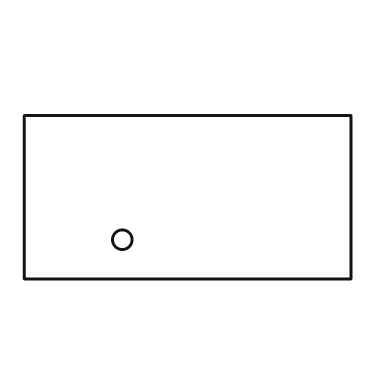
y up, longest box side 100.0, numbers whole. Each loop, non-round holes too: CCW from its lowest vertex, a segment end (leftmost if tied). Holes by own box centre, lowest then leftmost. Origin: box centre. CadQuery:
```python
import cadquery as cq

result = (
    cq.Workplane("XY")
    .moveTo(-50.0, -25.0)
    .lineTo(50.0, -25.0)
    .lineTo(50.0, 25.0)
    .lineTo(-50.0, 25.0)
    .close()
    .moveTo(-20.0, -13.0)
    .circle(3.0)
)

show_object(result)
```